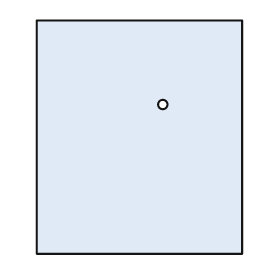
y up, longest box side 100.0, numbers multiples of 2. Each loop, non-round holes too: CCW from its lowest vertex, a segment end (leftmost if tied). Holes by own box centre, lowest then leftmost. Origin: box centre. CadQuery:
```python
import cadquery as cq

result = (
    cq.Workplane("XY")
    .moveTo(-44.0, -50.0)
    .lineTo(44.0, -50.0)
    .lineTo(44.0, 50.0)
    .lineTo(-44.0, 50.0)
    .close()
    .moveTo(10.0, 14.0)
    .circle(2.0)
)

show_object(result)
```